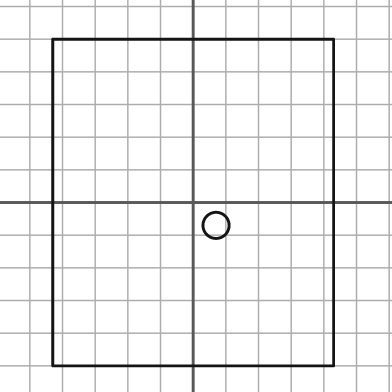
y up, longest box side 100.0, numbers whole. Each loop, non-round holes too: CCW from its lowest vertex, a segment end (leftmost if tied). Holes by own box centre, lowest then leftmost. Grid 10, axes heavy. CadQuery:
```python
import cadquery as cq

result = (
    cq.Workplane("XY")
    .moveTo(-43.0, -50.0)
    .lineTo(43.0, -50.0)
    .lineTo(43.0, 50.0)
    .lineTo(-43.0, 50.0)
    .close()
    .moveTo(7.0, -7.0)
    .circle(4.0)
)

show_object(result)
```